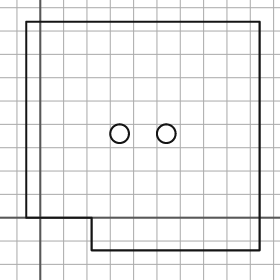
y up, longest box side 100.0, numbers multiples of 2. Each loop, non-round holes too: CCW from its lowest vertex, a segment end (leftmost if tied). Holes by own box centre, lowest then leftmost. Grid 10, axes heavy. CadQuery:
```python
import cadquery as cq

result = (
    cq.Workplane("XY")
    .moveTo(22.0, -14.0)
    .lineTo(94.0, -14.0)
    .lineTo(94.0, 84.0)
    .lineTo(-6.0, 84.0)
    .lineTo(-6.0, 0.0)
    .lineTo(22.0, 0.0)
    .close()
    .moveTo(34.0, 36.0)
    .circle(4.0)
    .moveTo(54.0, 36.0)
    .circle(4.0)
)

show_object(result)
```